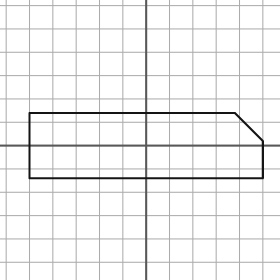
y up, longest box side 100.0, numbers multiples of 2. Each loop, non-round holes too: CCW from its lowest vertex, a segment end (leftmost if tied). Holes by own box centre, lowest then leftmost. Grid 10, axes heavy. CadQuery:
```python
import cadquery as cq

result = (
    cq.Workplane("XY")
    .moveTo(-50.0, -14.0)
    .lineTo(50.0, -14.0)
    .lineTo(50.0, 2.0)
    .lineTo(38.0, 14.0)
    .lineTo(-50.0, 14.0)
    .close()
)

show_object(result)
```